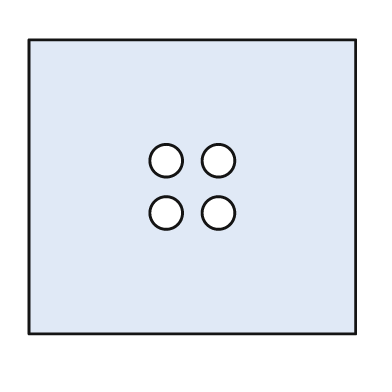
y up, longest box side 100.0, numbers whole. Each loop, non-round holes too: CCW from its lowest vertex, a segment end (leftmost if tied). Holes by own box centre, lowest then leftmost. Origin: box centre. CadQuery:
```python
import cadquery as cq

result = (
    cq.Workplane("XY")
    .moveTo(-50.0, -45.0)
    .lineTo(50.0, -45.0)
    .lineTo(50.0, 45.0)
    .lineTo(-50.0, 45.0)
    .close()
    .moveTo(-8.0, -8.0)
    .circle(5.0)
    .moveTo(8.0, -8.0)
    .circle(5.0)
    .moveTo(-8.0, 8.0)
    .circle(5.0)
    .moveTo(8.0, 8.0)
    .circle(5.0)
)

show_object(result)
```